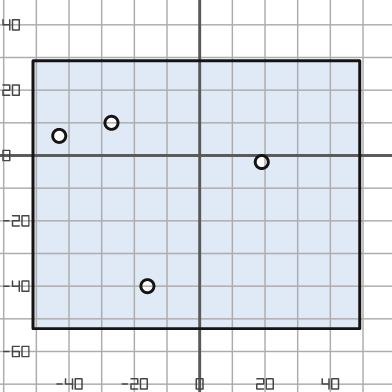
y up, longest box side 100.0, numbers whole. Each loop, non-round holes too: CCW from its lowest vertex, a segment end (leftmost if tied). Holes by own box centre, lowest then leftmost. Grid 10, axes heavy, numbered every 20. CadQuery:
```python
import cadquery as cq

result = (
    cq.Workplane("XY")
    .moveTo(-51.0, -53.0)
    .lineTo(49.0, -53.0)
    .lineTo(49.0, 29.0)
    .lineTo(-51.0, 29.0)
    .close()
    .moveTo(-16.0, -40.0)
    .circle(2.0)
    .moveTo(19.0, -2.0)
    .circle(2.0)
    .moveTo(-43.0, 6.0)
    .circle(2.0)
    .moveTo(-27.0, 10.0)
    .circle(2.0)
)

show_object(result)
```